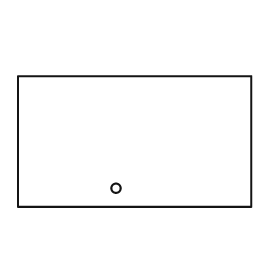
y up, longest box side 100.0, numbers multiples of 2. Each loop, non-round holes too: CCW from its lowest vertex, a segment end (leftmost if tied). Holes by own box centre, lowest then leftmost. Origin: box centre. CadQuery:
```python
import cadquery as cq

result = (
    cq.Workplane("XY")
    .moveTo(-50.0, -28.0)
    .lineTo(50.0, -28.0)
    .lineTo(50.0, 28.0)
    .lineTo(-50.0, 28.0)
    .close()
    .moveTo(-8.0, -20.0)
    .circle(2.0)
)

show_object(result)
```